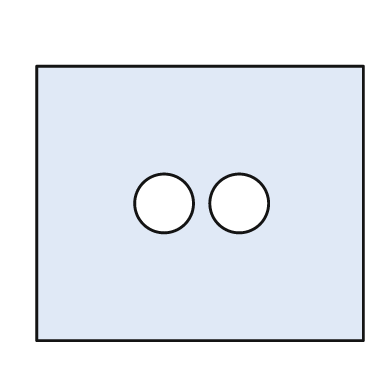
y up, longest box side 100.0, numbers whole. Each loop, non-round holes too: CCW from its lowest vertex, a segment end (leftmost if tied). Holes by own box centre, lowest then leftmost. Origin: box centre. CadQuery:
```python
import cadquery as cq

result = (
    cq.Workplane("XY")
    .moveTo(-50.0, -42.0)
    .lineTo(50.0, -42.0)
    .lineTo(50.0, 42.0)
    .lineTo(-50.0, 42.0)
    .close()
    .moveTo(-11.0, 0.0)
    .circle(9.0)
    .moveTo(12.0, 0.0)
    .circle(9.0)
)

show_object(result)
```